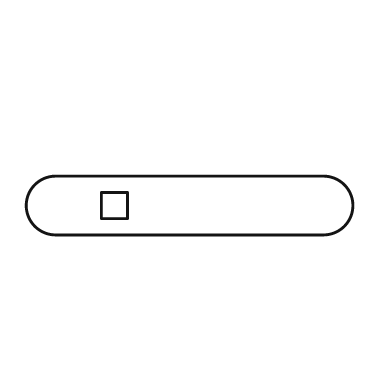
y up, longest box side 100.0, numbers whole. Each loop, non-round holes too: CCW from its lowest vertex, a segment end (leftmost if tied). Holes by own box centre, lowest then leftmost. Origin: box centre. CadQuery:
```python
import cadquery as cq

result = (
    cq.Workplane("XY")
    .moveTo(-41.0, -9.0)
    .lineTo(41.0, -9.0)
    .threePointArc((50.0, 0.0), (41.0, 9.0))
    .lineTo(-41.0, 9.0)
    .threePointArc((-50.0, 0.0), (-41.0, -9.0))
    .close()
    .moveTo(-27.0, -4.0)
    .lineTo(-19.0, -4.0)
    .lineTo(-19.0, 4.0)
    .lineTo(-27.0, 4.0)
    .close()
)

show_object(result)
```